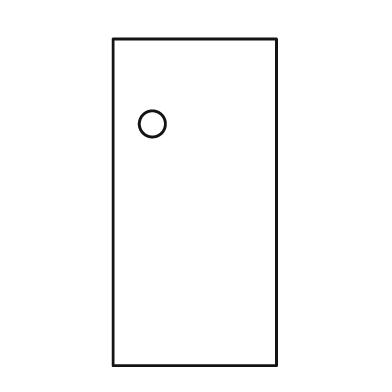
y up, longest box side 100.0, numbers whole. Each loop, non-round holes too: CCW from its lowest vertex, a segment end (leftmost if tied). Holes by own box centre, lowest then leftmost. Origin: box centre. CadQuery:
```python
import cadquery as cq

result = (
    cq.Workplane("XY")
    .moveTo(-25.0, -50.0)
    .lineTo(25.0, -50.0)
    .lineTo(25.0, 50.0)
    .lineTo(-25.0, 50.0)
    .close()
    .moveTo(-13.0, 24.0)
    .circle(4.0)
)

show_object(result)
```